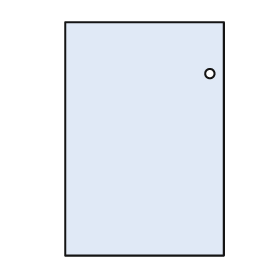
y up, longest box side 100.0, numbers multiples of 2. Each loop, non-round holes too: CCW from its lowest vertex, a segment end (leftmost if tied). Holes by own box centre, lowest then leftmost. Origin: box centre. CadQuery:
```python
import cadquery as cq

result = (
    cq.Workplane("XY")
    .moveTo(-34.0, -50.0)
    .lineTo(34.0, -50.0)
    .lineTo(34.0, 50.0)
    .lineTo(-34.0, 50.0)
    .close()
    .moveTo(28.0, 28.0)
    .circle(2.0)
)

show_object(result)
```